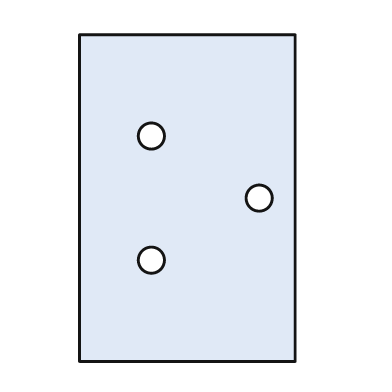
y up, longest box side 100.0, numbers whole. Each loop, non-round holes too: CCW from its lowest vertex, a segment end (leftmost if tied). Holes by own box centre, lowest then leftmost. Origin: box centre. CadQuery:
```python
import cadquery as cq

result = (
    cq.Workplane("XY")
    .moveTo(-33.0, -50.0)
    .lineTo(33.0, -50.0)
    .lineTo(33.0, 50.0)
    .lineTo(-33.0, 50.0)
    .close()
    .moveTo(-11.0, -19.0)
    .circle(4.0)
    .moveTo(22.0, 0.0)
    .circle(4.0)
    .moveTo(-11.0, 19.0)
    .circle(4.0)
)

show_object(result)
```